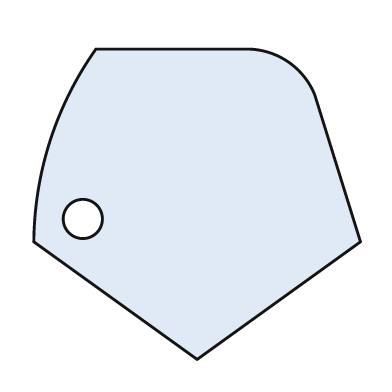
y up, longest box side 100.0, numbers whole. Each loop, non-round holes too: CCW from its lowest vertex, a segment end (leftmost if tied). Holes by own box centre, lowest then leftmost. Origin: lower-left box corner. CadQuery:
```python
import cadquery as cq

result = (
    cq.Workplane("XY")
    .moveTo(50.0, 0.0)
    .lineTo(100.0, 36.0)
    .lineTo(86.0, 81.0)
    .threePointArc((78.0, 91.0), (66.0, 95.0))
    .lineTo(19.0, 95.0)
    .threePointArc((5.0, 67.0), (0.0, 36.0))
    .close()
    .moveTo(15.0, 43.0)
    .circle(6.0)
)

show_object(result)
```